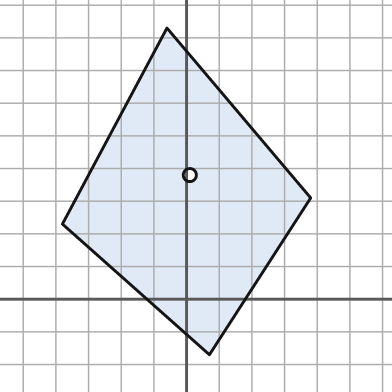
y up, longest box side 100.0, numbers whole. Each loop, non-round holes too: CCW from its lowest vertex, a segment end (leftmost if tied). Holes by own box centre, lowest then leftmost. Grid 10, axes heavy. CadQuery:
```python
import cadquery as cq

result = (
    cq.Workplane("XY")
    .moveTo(7.0, -17.0)
    .lineTo(38.0, 31.0)
    .lineTo(-6.0, 83.0)
    .lineTo(-38.0, 23.0)
    .close()
    .moveTo(1.0, 38.0)
    .circle(2.0)
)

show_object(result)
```